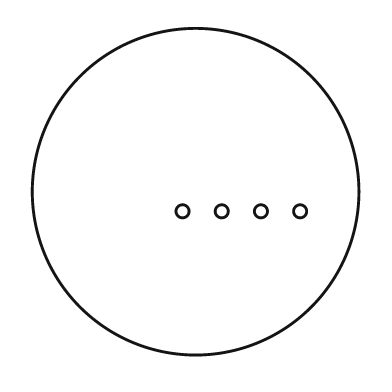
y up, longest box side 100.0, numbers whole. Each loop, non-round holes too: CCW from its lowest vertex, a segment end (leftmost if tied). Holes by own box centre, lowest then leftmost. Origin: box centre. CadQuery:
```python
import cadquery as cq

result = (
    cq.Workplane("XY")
    .moveTo(0.0, 0.0)
    .circle(50.0)
    .moveTo(-4.0, -6.0)
    .circle(2.0)
    .moveTo(8.0, -6.0)
    .circle(2.0)
    .moveTo(20.0, -6.0)
    .circle(2.0)
    .moveTo(32.0, -6.0)
    .circle(2.0)
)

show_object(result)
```